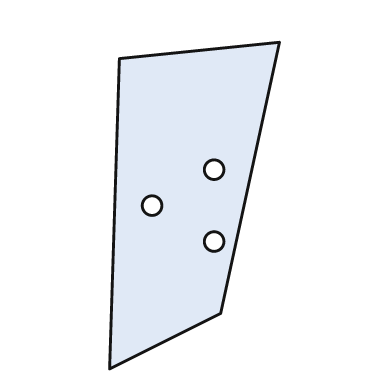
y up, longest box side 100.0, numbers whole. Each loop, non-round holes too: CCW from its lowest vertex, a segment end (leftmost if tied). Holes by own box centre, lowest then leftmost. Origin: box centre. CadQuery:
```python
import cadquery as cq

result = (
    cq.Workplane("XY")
    .moveTo(-26.0, -50.0)
    .lineTo(8.0, -33.0)
    .lineTo(26.0, 50.0)
    .lineTo(-23.0, 45.0)
    .close()
    .moveTo(6.0, -11.0)
    .circle(3.0)
    .moveTo(-13.0, 0.0)
    .circle(3.0)
    .moveTo(6.0, 11.0)
    .circle(3.0)
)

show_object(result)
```